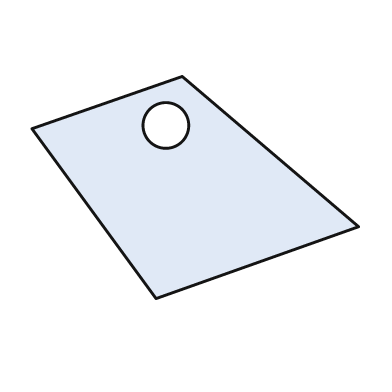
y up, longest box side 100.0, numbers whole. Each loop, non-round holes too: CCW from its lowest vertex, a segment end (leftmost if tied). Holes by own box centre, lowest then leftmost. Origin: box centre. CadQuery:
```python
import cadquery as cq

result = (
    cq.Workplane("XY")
    .moveTo(-12.0, -34.0)
    .lineTo(50.0, -12.0)
    .lineTo(-4.0, 34.0)
    .lineTo(-50.0, 18.0)
    .close()
    .moveTo(-9.0, 19.0)
    .circle(7.0)
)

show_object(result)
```